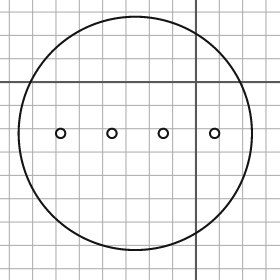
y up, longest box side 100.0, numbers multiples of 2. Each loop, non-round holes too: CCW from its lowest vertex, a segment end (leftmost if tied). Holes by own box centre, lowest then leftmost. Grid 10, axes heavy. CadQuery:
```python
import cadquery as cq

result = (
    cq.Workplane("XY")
    .moveTo(-26.0, -22.0)
    .circle(50.0)
    .moveTo(-58.0, -22.0)
    .circle(2.0)
    .moveTo(-36.0, -22.0)
    .circle(2.0)
    .moveTo(-14.0, -22.0)
    .circle(2.0)
    .moveTo(8.0, -22.0)
    .circle(2.0)
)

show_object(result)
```